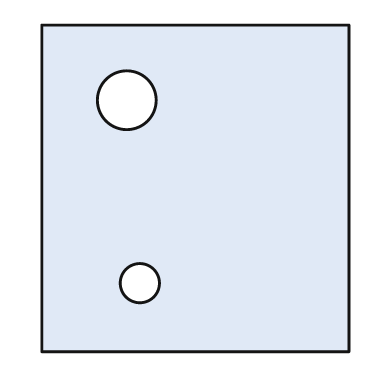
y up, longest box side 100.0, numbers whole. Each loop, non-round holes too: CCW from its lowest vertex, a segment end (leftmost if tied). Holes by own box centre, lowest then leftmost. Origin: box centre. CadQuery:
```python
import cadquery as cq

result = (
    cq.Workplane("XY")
    .moveTo(-47.0, -50.0)
    .lineTo(47.0, -50.0)
    .lineTo(47.0, 50.0)
    .lineTo(-47.0, 50.0)
    .close()
    .moveTo(-17.0, -29.0)
    .circle(6.0)
    .moveTo(-21.0, 27.0)
    .circle(9.0)
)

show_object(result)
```